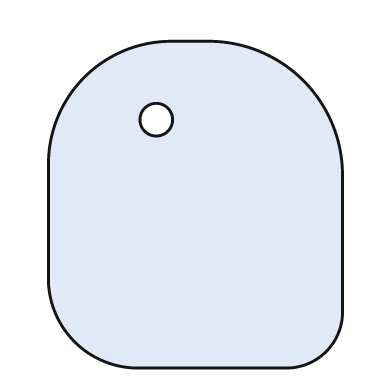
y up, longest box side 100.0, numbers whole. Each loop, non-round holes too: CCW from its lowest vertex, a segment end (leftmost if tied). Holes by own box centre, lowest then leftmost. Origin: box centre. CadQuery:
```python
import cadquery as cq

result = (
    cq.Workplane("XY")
    .moveTo(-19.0, -50.0)
    .lineTo(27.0, -50.0)
    .threePointArc((40.0, -45.0), (45.0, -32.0))
    .lineTo(45.0, 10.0)
    .threePointArc((33.0, 38.0), (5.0, 50.0))
    .lineTo(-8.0, 50.0)
    .threePointArc((-34.0, 39.0), (-45.0, 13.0))
    .lineTo(-45.0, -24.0)
    .threePointArc((-37.0, -42.0), (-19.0, -50.0))
    .close()
    .moveTo(-12.0, 26.0)
    .circle(5.0)
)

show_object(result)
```